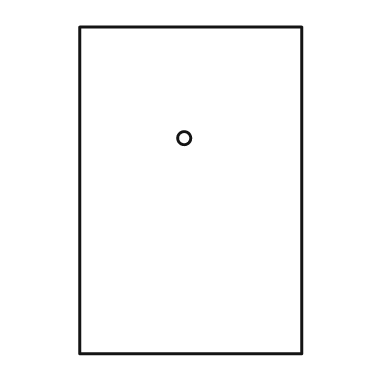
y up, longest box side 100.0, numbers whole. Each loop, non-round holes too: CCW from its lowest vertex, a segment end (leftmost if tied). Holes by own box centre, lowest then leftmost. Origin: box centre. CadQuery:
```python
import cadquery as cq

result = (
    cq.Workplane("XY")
    .moveTo(-34.0, -50.0)
    .lineTo(34.0, -50.0)
    .lineTo(34.0, 50.0)
    .lineTo(-34.0, 50.0)
    .close()
    .moveTo(-2.0, 16.0)
    .circle(2.0)
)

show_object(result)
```